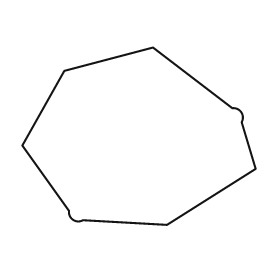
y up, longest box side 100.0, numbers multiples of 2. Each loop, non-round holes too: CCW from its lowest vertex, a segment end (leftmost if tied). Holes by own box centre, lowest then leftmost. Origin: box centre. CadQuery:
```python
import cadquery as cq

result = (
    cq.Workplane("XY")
    .moveTo(12.0, -38.0)
    .lineTo(50.0, -14.0)
    .lineTo(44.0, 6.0)
    .threePointArc((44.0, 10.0), (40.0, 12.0))
    .lineTo(6.0, 38.0)
    .lineTo(-32.0, 28.0)
    .lineTo(-50.0, -4.0)
    .lineTo(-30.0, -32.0)
    .threePointArc((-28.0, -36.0), (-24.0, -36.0))
    .close()
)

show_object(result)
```